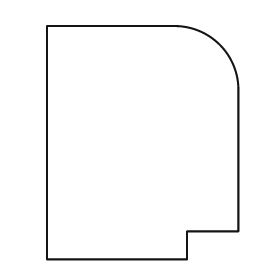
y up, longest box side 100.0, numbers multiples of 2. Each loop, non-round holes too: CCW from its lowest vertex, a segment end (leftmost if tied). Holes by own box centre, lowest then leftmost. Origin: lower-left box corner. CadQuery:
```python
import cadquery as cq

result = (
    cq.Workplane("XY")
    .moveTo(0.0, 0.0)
    .lineTo(60.0, 0.0)
    .lineTo(60.0, 12.0)
    .lineTo(82.0, 12.0)
    .lineTo(82.0, 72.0)
    .threePointArc((74.0, 92.0), (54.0, 100.0))
    .lineTo(0.0, 100.0)
    .close()
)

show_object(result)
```